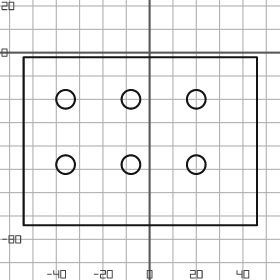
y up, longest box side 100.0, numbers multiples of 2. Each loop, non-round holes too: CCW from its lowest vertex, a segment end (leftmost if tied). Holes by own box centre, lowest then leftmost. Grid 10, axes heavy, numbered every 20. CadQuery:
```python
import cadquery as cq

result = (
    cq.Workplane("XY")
    .moveTo(-54.0, -74.0)
    .lineTo(46.0, -74.0)
    .lineTo(46.0, -2.0)
    .lineTo(-54.0, -2.0)
    .close()
    .moveTo(-36.0, -48.0)
    .circle(4.0)
    .moveTo(-8.0, -48.0)
    .circle(4.0)
    .moveTo(20.0, -48.0)
    .circle(4.0)
    .moveTo(-36.0, -20.0)
    .circle(4.0)
    .moveTo(-8.0, -20.0)
    .circle(4.0)
    .moveTo(20.0, -20.0)
    .circle(4.0)
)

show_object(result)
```